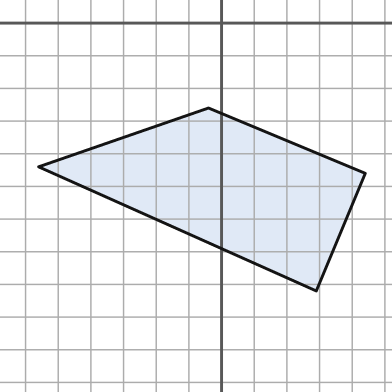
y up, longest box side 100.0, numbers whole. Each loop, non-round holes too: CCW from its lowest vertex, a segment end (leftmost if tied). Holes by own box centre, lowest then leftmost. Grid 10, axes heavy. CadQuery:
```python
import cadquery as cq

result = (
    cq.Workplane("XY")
    .moveTo(29.0, -82.0)
    .lineTo(44.0, -46.0)
    .lineTo(-4.0, -26.0)
    .lineTo(-56.0, -44.0)
    .close()
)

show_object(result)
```